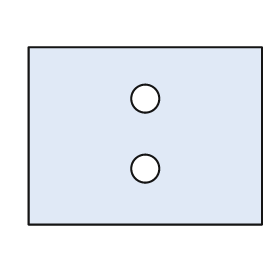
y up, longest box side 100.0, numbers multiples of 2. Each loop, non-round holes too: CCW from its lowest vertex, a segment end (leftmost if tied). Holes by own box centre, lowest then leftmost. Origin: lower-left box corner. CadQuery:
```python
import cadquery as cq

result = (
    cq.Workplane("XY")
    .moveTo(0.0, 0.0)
    .lineTo(100.0, 0.0)
    .lineTo(100.0, 76.0)
    .lineTo(0.0, 76.0)
    .close()
    .moveTo(50.0, 24.0)
    .circle(6.0)
    .moveTo(50.0, 54.0)
    .circle(6.0)
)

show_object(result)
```